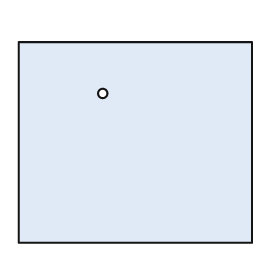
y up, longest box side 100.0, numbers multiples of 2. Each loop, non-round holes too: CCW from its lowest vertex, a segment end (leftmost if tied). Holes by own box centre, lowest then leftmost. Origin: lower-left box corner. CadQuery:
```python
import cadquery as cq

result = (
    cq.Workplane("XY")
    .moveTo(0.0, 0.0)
    .lineTo(100.0, 0.0)
    .lineTo(100.0, 86.0)
    .lineTo(0.0, 86.0)
    .close()
    .moveTo(36.0, 64.0)
    .circle(2.0)
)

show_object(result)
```